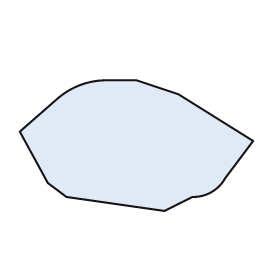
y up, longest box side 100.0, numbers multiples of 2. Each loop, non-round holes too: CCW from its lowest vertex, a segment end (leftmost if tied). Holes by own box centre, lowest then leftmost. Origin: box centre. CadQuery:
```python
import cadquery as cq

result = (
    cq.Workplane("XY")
    .moveTo(12.0, -28.0)
    .lineTo(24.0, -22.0)
    .threePointArc((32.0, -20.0), (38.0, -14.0))
    .lineTo(50.0, 2.0)
    .lineTo(18.0, 22.0)
    .lineTo(0.0, 28.0)
    .lineTo(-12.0, 28.0)
    .threePointArc((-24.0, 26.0), (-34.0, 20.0))
    .lineTo(-50.0, 6.0)
    .lineTo(-38.0, -16.0)
    .lineTo(-30.0, -22.0)
    .close()
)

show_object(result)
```